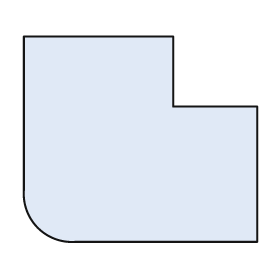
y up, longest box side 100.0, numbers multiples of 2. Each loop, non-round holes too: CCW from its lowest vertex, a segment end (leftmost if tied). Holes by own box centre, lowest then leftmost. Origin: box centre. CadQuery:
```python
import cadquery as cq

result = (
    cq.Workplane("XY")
    .moveTo(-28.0, -44.0)
    .lineTo(50.0, -44.0)
    .lineTo(50.0, 14.0)
    .lineTo(14.0, 14.0)
    .lineTo(14.0, 44.0)
    .lineTo(-50.0, 44.0)
    .lineTo(-50.0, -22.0)
    .threePointArc((-44.0, -38.0), (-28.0, -44.0))
    .close()
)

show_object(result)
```